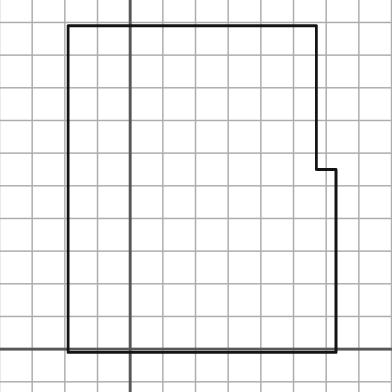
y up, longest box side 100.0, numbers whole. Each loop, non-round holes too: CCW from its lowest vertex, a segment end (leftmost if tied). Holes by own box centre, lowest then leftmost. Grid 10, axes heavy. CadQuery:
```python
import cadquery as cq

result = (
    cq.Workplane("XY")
    .moveTo(-19.0, -1.0)
    .lineTo(63.0, -1.0)
    .lineTo(63.0, 55.0)
    .lineTo(57.0, 55.0)
    .lineTo(57.0, 99.0)
    .lineTo(-19.0, 99.0)
    .close()
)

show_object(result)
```